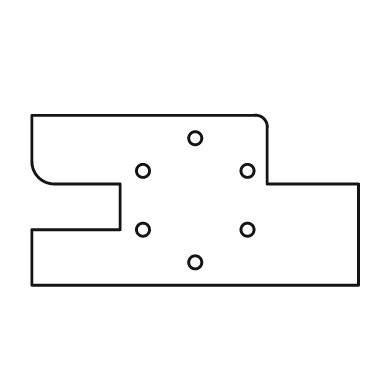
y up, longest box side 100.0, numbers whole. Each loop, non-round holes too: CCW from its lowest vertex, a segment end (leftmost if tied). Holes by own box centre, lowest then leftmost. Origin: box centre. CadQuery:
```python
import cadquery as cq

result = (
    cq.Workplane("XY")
    .moveTo(-50.0, -26.0)
    .lineTo(50.0, -26.0)
    .lineTo(50.0, 5.0)
    .lineTo(22.0, 5.0)
    .lineTo(22.0, 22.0)
    .threePointArc((21.0, 25.0), (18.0, 26.0))
    .lineTo(-50.0, 26.0)
    .lineTo(-50.0, 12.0)
    .threePointArc((-48.0, 7.0), (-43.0, 5.0))
    .lineTo(-23.0, 5.0)
    .lineTo(-23.0, -9.0)
    .lineTo(-50.0, -9.0)
    .close()
    .moveTo(0.0, -19.0)
    .circle(2.0)
    .moveTo(-16.0, -9.0)
    .circle(2.0)
    .moveTo(16.0, -9.0)
    .circle(2.0)
    .moveTo(-16.0, 9.0)
    .circle(2.0)
    .moveTo(16.0, 9.0)
    .circle(2.0)
    .moveTo(0.0, 19.0)
    .circle(2.0)
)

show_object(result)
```